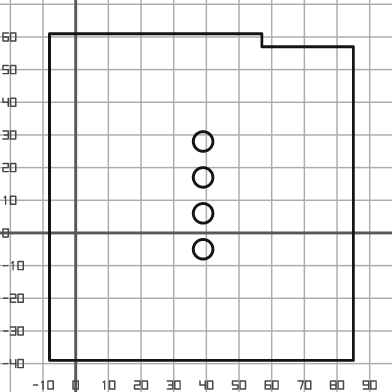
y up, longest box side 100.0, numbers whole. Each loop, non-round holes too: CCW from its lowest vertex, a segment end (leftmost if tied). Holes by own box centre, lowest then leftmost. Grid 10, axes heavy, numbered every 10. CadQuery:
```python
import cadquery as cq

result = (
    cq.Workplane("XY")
    .moveTo(-8.0, -39.0)
    .lineTo(85.0, -39.0)
    .lineTo(85.0, 57.0)
    .lineTo(57.0, 57.0)
    .lineTo(57.0, 61.0)
    .lineTo(-8.0, 61.0)
    .close()
    .moveTo(39.0, -5.0)
    .circle(3.0)
    .moveTo(39.0, 6.0)
    .circle(3.0)
    .moveTo(39.0, 17.0)
    .circle(3.0)
    .moveTo(39.0, 28.0)
    .circle(3.0)
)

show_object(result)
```